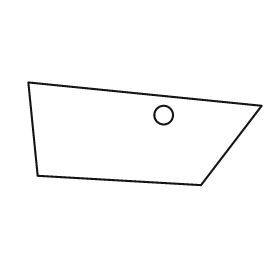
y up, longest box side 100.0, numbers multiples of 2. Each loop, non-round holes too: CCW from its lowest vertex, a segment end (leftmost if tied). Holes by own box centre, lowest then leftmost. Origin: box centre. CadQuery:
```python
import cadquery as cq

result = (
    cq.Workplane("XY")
    .moveTo(24.0, -22.0)
    .lineTo(50.0, 12.0)
    .lineTo(-50.0, 22.0)
    .lineTo(-46.0, -18.0)
    .close()
    .moveTo(8.0, 8.0)
    .circle(4.0)
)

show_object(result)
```